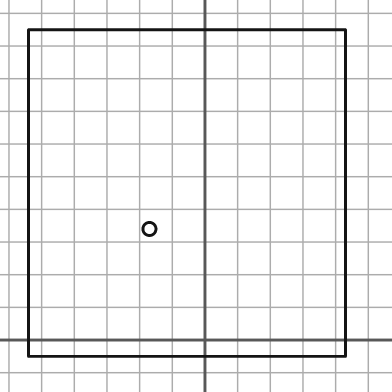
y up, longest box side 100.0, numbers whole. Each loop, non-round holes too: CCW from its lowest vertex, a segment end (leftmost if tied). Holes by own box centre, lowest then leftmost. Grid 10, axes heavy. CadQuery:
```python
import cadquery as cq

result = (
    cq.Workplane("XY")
    .moveTo(-54.0, -5.0)
    .lineTo(43.0, -5.0)
    .lineTo(43.0, 95.0)
    .lineTo(-54.0, 95.0)
    .close()
    .moveTo(-17.0, 34.0)
    .circle(2.0)
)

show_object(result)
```